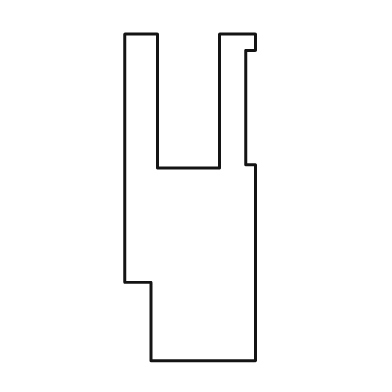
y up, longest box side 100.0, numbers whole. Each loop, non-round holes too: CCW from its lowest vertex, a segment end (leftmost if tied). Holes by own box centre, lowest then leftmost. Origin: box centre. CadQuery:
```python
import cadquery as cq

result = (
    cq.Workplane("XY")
    .moveTo(-12.0, -50.0)
    .lineTo(20.0, -50.0)
    .lineTo(20.0, 10.0)
    .lineTo(17.0, 10.0)
    .lineTo(17.0, 45.0)
    .lineTo(20.0, 45.0)
    .lineTo(20.0, 50.0)
    .lineTo(9.0, 50.0)
    .lineTo(9.0, 9.0)
    .lineTo(-10.0, 9.0)
    .lineTo(-10.0, 50.0)
    .lineTo(-20.0, 50.0)
    .lineTo(-20.0, -26.0)
    .lineTo(-12.0, -26.0)
    .close()
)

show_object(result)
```